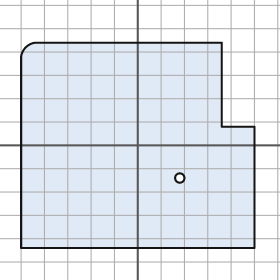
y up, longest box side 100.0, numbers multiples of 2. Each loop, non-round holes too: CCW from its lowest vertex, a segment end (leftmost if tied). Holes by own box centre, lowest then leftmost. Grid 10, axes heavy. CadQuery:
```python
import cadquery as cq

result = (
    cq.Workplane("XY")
    .moveTo(-50.0, -44.0)
    .lineTo(50.0, -44.0)
    .lineTo(50.0, 8.0)
    .lineTo(36.0, 8.0)
    .lineTo(36.0, 44.0)
    .lineTo(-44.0, 44.0)
    .threePointArc((-48.0, 42.0), (-50.0, 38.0))
    .close()
    .moveTo(18.0, -14.0)
    .circle(2.0)
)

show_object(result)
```